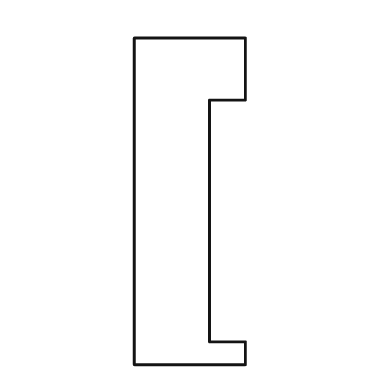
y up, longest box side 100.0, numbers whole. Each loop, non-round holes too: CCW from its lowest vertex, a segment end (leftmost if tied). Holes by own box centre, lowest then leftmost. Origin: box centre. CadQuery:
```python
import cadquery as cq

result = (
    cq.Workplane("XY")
    .moveTo(-17.0, -50.0)
    .lineTo(17.0, -50.0)
    .lineTo(17.0, -43.0)
    .lineTo(6.0, -43.0)
    .lineTo(6.0, 31.0)
    .lineTo(17.0, 31.0)
    .lineTo(17.0, 50.0)
    .lineTo(-17.0, 50.0)
    .close()
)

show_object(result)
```